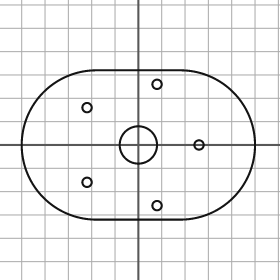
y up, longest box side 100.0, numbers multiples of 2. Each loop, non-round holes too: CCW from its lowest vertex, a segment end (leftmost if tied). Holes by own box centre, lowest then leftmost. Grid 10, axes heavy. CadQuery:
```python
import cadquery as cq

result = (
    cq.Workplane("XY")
    .moveTo(-18.0, -32.0)
    .lineTo(18.0, -32.0)
    .threePointArc((50.0, 0.0), (18.0, 32.0))
    .lineTo(-18.0, 32.0)
    .threePointArc((-50.0, 0.0), (-18.0, -32.0))
    .close()
    .moveTo(8.0, -26.0)
    .circle(2.0)
    .moveTo(-22.0, -16.0)
    .circle(2.0)
    .moveTo(0.0, 0.0)
    .circle(8.0)
    .moveTo(26.0, 0.0)
    .circle(2.0)
    .moveTo(-22.0, 16.0)
    .circle(2.0)
    .moveTo(8.0, 26.0)
    .circle(2.0)
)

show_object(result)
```